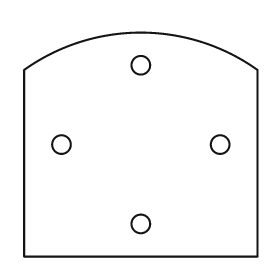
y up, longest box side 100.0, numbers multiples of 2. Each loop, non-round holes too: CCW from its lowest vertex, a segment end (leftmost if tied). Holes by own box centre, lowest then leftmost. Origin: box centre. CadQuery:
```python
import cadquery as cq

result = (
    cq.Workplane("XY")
    .moveTo(-50.0, -48.0)
    .lineTo(50.0, -48.0)
    .lineTo(50.0, 32.0)
    .threePointArc((0.0, 48.0), (-50.0, 32.0))
    .close()
    .moveTo(0.0, -34.0)
    .circle(4.0)
    .moveTo(-34.0, 0.0)
    .circle(4.0)
    .moveTo(34.0, 0.0)
    .circle(4.0)
    .moveTo(0.0, 34.0)
    .circle(4.0)
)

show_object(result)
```